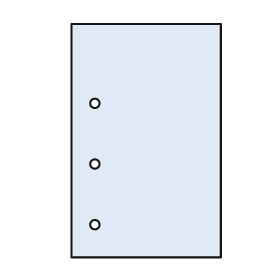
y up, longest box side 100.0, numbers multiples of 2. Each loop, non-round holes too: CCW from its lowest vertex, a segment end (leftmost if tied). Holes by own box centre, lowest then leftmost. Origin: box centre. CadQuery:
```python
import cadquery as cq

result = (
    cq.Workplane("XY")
    .moveTo(-32.0, -50.0)
    .lineTo(32.0, -50.0)
    .lineTo(32.0, 50.0)
    .lineTo(-32.0, 50.0)
    .close()
    .moveTo(-22.0, -36.0)
    .circle(2.0)
    .moveTo(-22.0, -10.0)
    .circle(2.0)
    .moveTo(-22.0, 16.0)
    .circle(2.0)
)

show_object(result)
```